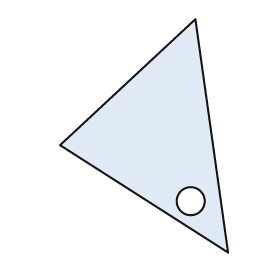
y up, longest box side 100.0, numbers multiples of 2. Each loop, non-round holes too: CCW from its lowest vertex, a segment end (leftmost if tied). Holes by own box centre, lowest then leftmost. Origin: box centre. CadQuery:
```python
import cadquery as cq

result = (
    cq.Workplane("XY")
    .moveTo(36.0, -50.0)
    .lineTo(22.0, 50.0)
    .lineTo(-36.0, -4.0)
    .close()
    .moveTo(20.0, -28.0)
    .circle(6.0)
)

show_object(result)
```